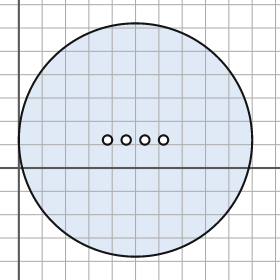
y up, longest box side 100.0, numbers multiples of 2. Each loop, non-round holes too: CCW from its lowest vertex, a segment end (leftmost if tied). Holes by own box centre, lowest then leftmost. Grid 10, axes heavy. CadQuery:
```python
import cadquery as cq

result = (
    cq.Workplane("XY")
    .moveTo(50.0, 12.0)
    .circle(50.0)
    .moveTo(38.0, 12.0)
    .circle(2.0)
    .moveTo(46.0, 12.0)
    .circle(2.0)
    .moveTo(54.0, 12.0)
    .circle(2.0)
    .moveTo(62.0, 12.0)
    .circle(2.0)
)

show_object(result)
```